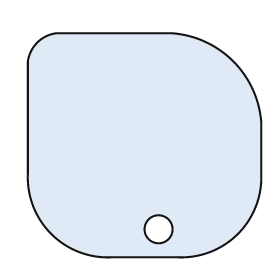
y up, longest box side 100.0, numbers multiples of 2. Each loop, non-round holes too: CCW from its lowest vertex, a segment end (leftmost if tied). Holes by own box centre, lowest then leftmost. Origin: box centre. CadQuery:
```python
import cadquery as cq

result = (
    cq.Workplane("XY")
    .moveTo(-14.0, -48.0)
    .lineTo(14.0, -48.0)
    .threePointArc((40.0, -38.0), (50.0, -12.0))
    .lineTo(50.0, 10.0)
    .threePointArc((38.0, 36.0), (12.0, 48.0))
    .lineTo(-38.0, 48.0)
    .threePointArc((-46.0, 44.0), (-50.0, 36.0))
    .lineTo(-50.0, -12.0)
    .threePointArc((-40.0, -38.0), (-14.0, -48.0))
    .close()
    .moveTo(6.0, -36.0)
    .circle(6.0)
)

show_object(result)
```